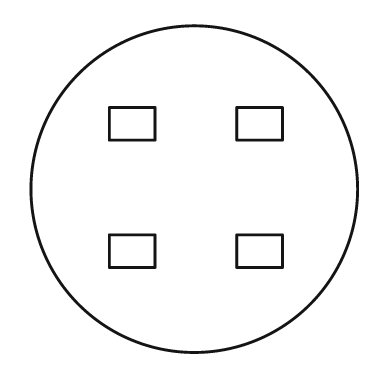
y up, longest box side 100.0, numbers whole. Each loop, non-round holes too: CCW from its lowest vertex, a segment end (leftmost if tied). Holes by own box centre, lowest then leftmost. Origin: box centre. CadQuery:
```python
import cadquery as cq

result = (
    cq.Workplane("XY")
    .moveTo(0.0, 0.0)
    .circle(50.0)
    .moveTo(-26.0, -24.0)
    .lineTo(-12.0, -24.0)
    .lineTo(-12.0, -14.0)
    .lineTo(-26.0, -14.0)
    .close()
    .moveTo(13.0, -24.0)
    .lineTo(27.0, -24.0)
    .lineTo(27.0, -14.0)
    .lineTo(13.0, -14.0)
    .close()
    .moveTo(-26.0, 15.0)
    .lineTo(-12.0, 15.0)
    .lineTo(-12.0, 25.0)
    .lineTo(-26.0, 25.0)
    .close()
    .moveTo(13.0, 15.0)
    .lineTo(27.0, 15.0)
    .lineTo(27.0, 25.0)
    .lineTo(13.0, 25.0)
    .close()
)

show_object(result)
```